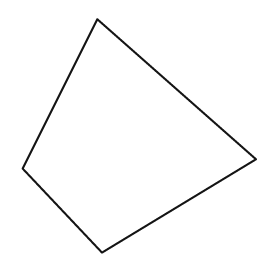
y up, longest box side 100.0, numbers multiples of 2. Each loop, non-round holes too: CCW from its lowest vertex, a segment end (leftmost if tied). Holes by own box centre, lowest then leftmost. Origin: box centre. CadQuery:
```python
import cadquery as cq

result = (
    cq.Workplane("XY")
    .moveTo(-16.0, -50.0)
    .lineTo(50.0, -10.0)
    .lineTo(-18.0, 50.0)
    .lineTo(-50.0, -14.0)
    .close()
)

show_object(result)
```